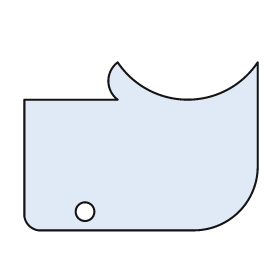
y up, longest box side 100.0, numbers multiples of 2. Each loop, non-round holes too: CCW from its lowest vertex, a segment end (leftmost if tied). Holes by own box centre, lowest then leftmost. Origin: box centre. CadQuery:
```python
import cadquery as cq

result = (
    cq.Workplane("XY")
    .moveTo(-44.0, -36.0)
    .lineTo(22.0, -36.0)
    .threePointArc((42.0, -28.0), (50.0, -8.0))
    .lineTo(50.0, 36.0)
    .threePointArc((20.0, 20.0), (-10.0, 36.0))
    .threePointArc((-14.0, 28.0), (-10.0, 20.0))
    .lineTo(-50.0, 20.0)
    .lineTo(-50.0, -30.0)
    .threePointArc((-48.0, -34.0), (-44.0, -36.0))
    .close()
    .moveTo(-24.0, -28.0)
    .circle(4.0)
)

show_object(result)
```